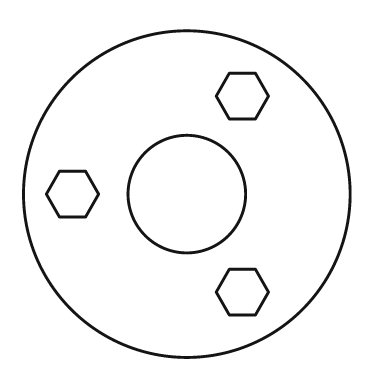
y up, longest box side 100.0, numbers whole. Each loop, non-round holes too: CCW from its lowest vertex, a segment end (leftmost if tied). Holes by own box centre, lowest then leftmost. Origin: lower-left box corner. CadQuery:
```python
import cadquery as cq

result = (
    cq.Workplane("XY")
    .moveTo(50.0, 50.0)
    .circle(50.0)
    .moveTo(63.0, 13.0)
    .lineTo(71.0, 13.0)
    .lineTo(75.0, 20.0)
    .lineTo(71.0, 27.0)
    .lineTo(63.0, 27.0)
    .lineTo(59.0, 20.0)
    .close()
    .moveTo(11.0, 43.0)
    .lineTo(19.0, 43.0)
    .lineTo(23.0, 50.0)
    .lineTo(19.0, 57.0)
    .lineTo(11.0, 57.0)
    .lineTo(7.0, 50.0)
    .close()
    .moveTo(50.0, 50.0)
    .circle(18.0)
    .moveTo(63.0, 73.0)
    .lineTo(71.0, 73.0)
    .lineTo(75.0, 80.0)
    .lineTo(71.0, 87.0)
    .lineTo(63.0, 87.0)
    .lineTo(59.0, 80.0)
    .close()
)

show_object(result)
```